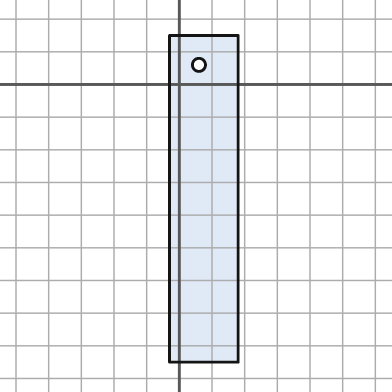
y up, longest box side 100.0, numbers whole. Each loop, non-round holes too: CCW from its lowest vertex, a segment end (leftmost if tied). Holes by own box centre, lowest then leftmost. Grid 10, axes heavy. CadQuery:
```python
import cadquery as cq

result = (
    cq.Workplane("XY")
    .moveTo(-3.0, -85.0)
    .lineTo(18.0, -85.0)
    .lineTo(18.0, 15.0)
    .lineTo(-3.0, 15.0)
    .close()
    .moveTo(6.0, 6.0)
    .circle(2.0)
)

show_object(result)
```